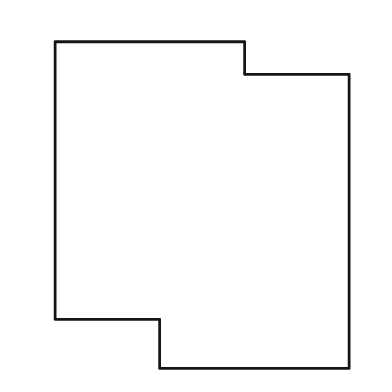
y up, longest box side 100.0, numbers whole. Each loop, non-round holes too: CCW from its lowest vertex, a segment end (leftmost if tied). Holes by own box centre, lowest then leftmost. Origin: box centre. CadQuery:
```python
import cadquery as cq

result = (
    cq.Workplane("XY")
    .moveTo(-13.0, -50.0)
    .lineTo(45.0, -50.0)
    .lineTo(45.0, 40.0)
    .lineTo(13.0, 40.0)
    .lineTo(13.0, 50.0)
    .lineTo(-45.0, 50.0)
    .lineTo(-45.0, -35.0)
    .lineTo(-13.0, -35.0)
    .close()
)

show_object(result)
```